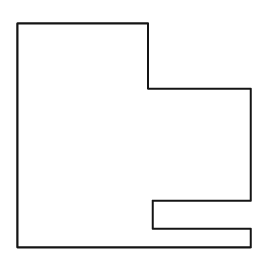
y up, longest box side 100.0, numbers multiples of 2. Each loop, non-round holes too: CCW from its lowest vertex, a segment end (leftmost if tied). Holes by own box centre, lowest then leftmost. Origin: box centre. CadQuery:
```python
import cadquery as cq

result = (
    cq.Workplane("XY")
    .moveTo(-50.0, -48.0)
    .lineTo(50.0, -48.0)
    .lineTo(50.0, -40.0)
    .lineTo(8.0, -40.0)
    .lineTo(8.0, -28.0)
    .lineTo(50.0, -28.0)
    .lineTo(50.0, 20.0)
    .lineTo(6.0, 20.0)
    .lineTo(6.0, 48.0)
    .lineTo(-50.0, 48.0)
    .close()
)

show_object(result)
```